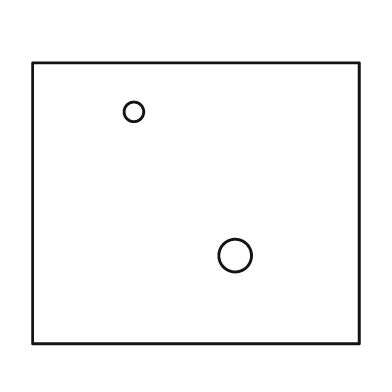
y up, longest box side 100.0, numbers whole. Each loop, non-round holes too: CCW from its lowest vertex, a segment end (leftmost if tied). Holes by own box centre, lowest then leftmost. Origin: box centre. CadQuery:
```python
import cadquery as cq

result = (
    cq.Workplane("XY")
    .moveTo(-50.0, -43.0)
    .lineTo(50.0, -43.0)
    .lineTo(50.0, 43.0)
    .lineTo(-50.0, 43.0)
    .close()
    .moveTo(12.0, -16.0)
    .circle(5.0)
    .moveTo(-19.0, 28.0)
    .circle(3.0)
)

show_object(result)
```